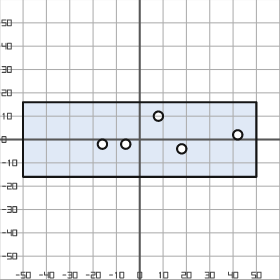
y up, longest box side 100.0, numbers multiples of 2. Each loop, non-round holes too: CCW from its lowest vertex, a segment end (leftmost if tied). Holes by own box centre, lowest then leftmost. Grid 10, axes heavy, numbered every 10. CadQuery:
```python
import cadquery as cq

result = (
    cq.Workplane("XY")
    .moveTo(-50.0, -16.0)
    .lineTo(50.0, -16.0)
    .lineTo(50.0, 16.0)
    .lineTo(-50.0, 16.0)
    .close()
    .moveTo(18.0, -4.0)
    .circle(2.0)
    .moveTo(-16.0, -2.0)
    .circle(2.0)
    .moveTo(-6.0, -2.0)
    .circle(2.0)
    .moveTo(42.0, 2.0)
    .circle(2.0)
    .moveTo(8.0, 10.0)
    .circle(2.0)
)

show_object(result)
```